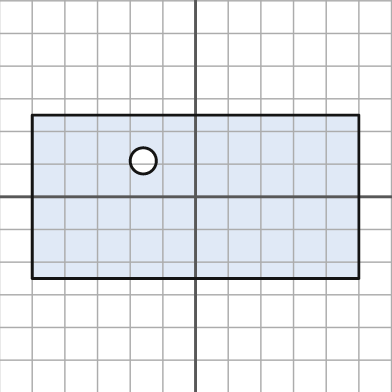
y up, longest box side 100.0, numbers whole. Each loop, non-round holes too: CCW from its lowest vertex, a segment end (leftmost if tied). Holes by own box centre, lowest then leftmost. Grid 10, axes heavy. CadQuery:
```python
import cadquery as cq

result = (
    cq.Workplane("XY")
    .moveTo(-50.0, -25.0)
    .lineTo(50.0, -25.0)
    .lineTo(50.0, 25.0)
    .lineTo(-50.0, 25.0)
    .close()
    .moveTo(-16.0, 11.0)
    .circle(4.0)
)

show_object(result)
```